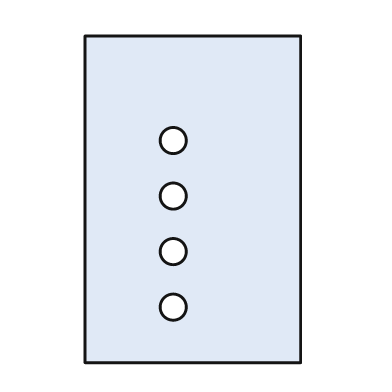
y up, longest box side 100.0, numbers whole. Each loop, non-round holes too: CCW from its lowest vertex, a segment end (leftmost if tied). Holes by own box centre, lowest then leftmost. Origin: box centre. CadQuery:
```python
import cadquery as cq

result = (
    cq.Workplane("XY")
    .moveTo(-33.0, -50.0)
    .lineTo(33.0, -50.0)
    .lineTo(33.0, 50.0)
    .lineTo(-33.0, 50.0)
    .close()
    .moveTo(-6.0, -33.0)
    .circle(4.0)
    .moveTo(-6.0, -16.0)
    .circle(4.0)
    .moveTo(-6.0, 1.0)
    .circle(4.0)
    .moveTo(-6.0, 18.0)
    .circle(4.0)
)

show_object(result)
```